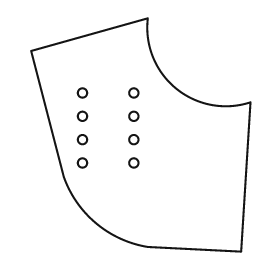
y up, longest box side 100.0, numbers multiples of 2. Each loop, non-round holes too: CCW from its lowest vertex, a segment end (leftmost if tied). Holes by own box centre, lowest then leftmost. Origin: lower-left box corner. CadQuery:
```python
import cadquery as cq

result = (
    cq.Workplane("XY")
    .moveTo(90.0, 0.0)
    .lineTo(94.0, 64.0)
    .threePointArc((62.0, 70.0), (50.0, 100.0))
    .lineTo(0.0, 86.0)
    .lineTo(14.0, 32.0)
    .threePointArc((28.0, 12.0), (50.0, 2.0))
    .close()
    .moveTo(22.0, 38.0)
    .circle(2.0)
    .moveTo(44.0, 38.0)
    .circle(2.0)
    .moveTo(22.0, 48.0)
    .circle(2.0)
    .moveTo(44.0, 48.0)
    .circle(2.0)
    .moveTo(22.0, 58.0)
    .circle(2.0)
    .moveTo(44.0, 58.0)
    .circle(2.0)
    .moveTo(22.0, 68.0)
    .circle(2.0)
    .moveTo(44.0, 68.0)
    .circle(2.0)
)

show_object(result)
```